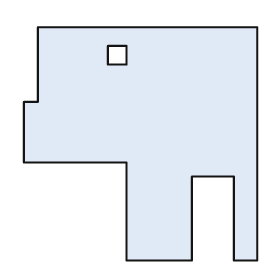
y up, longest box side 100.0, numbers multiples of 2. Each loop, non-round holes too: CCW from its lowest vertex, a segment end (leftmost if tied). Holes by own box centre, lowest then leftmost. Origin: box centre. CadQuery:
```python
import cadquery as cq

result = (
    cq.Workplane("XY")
    .moveTo(-6.0, -50.0)
    .lineTo(22.0, -50.0)
    .lineTo(22.0, -14.0)
    .lineTo(40.0, -14.0)
    .lineTo(40.0, -50.0)
    .lineTo(50.0, -50.0)
    .lineTo(50.0, 50.0)
    .lineTo(-44.0, 50.0)
    .lineTo(-44.0, 18.0)
    .lineTo(-50.0, 18.0)
    .lineTo(-50.0, -8.0)
    .lineTo(-6.0, -8.0)
    .close()
    .moveTo(-14.0, 34.0)
    .lineTo(-6.0, 34.0)
    .lineTo(-6.0, 42.0)
    .lineTo(-14.0, 42.0)
    .close()
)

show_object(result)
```